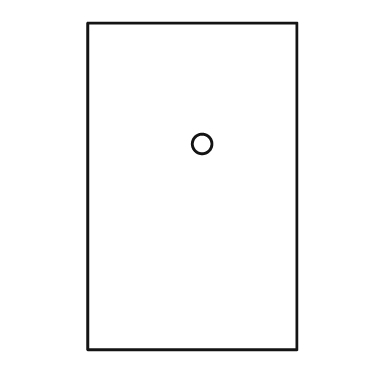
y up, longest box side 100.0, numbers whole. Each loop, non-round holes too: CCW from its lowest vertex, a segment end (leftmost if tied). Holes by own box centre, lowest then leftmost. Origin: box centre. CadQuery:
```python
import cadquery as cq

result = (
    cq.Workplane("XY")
    .moveTo(-32.0, -50.0)
    .lineTo(32.0, -50.0)
    .lineTo(32.0, 50.0)
    .lineTo(-32.0, 50.0)
    .close()
    .moveTo(3.0, 13.0)
    .circle(3.0)
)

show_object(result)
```